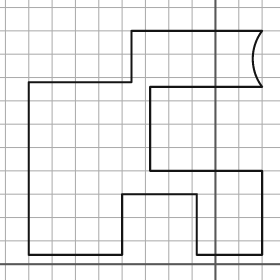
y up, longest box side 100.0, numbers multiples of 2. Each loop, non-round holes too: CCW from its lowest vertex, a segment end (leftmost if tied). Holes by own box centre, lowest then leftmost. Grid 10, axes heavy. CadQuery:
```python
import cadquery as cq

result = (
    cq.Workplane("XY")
    .moveTo(-80.0, 4.0)
    .lineTo(-40.0, 4.0)
    .lineTo(-40.0, 30.0)
    .lineTo(-8.0, 30.0)
    .lineTo(-8.0, 4.0)
    .lineTo(20.0, 4.0)
    .lineTo(20.0, 40.0)
    .lineTo(-28.0, 40.0)
    .lineTo(-28.0, 76.0)
    .lineTo(20.0, 76.0)
    .threePointArc((16.0, 88.0), (20.0, 100.0))
    .lineTo(-36.0, 100.0)
    .lineTo(-36.0, 78.0)
    .lineTo(-80.0, 78.0)
    .close()
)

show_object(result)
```